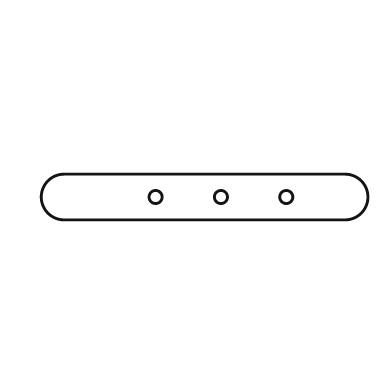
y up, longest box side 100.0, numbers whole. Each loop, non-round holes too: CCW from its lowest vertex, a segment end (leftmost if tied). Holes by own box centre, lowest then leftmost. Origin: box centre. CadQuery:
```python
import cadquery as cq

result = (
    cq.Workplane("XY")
    .moveTo(-43.0, -7.0)
    .lineTo(43.0, -7.0)
    .threePointArc((50.0, 0.0), (43.0, 7.0))
    .lineTo(-43.0, 7.0)
    .threePointArc((-50.0, 0.0), (-43.0, -7.0))
    .close()
    .moveTo(-15.0, 0.0)
    .circle(2.0)
    .moveTo(5.0, 0.0)
    .circle(2.0)
    .moveTo(25.0, 0.0)
    .circle(2.0)
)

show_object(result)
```